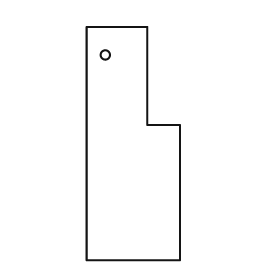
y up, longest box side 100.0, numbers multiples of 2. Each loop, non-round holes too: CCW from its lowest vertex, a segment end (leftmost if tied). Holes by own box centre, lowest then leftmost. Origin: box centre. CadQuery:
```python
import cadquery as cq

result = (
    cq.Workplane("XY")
    .moveTo(-20.0, -50.0)
    .lineTo(20.0, -50.0)
    .lineTo(20.0, 8.0)
    .lineTo(6.0, 8.0)
    .lineTo(6.0, 50.0)
    .lineTo(-20.0, 50.0)
    .close()
    .moveTo(-12.0, 38.0)
    .circle(2.0)
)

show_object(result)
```